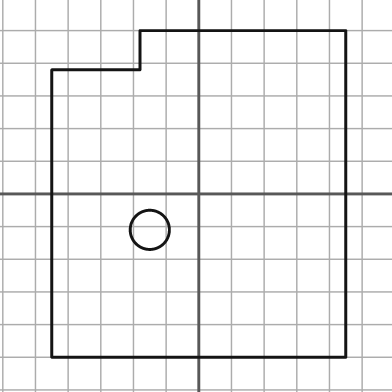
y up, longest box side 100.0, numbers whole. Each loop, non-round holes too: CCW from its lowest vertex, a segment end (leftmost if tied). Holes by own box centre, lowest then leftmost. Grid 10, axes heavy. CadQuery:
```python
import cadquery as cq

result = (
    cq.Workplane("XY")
    .moveTo(-45.0, -50.0)
    .lineTo(45.0, -50.0)
    .lineTo(45.0, 50.0)
    .lineTo(-18.0, 50.0)
    .lineTo(-18.0, 38.0)
    .lineTo(-45.0, 38.0)
    .close()
    .moveTo(-15.0, -11.0)
    .circle(6.0)
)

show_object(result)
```